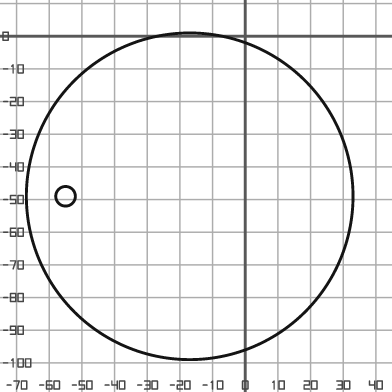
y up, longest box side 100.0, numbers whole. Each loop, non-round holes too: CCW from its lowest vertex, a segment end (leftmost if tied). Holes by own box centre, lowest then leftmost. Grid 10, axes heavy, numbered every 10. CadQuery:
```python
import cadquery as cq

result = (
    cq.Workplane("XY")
    .moveTo(-17.0, -49.0)
    .circle(50.0)
    .moveTo(-55.0, -49.0)
    .circle(3.0)
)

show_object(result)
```